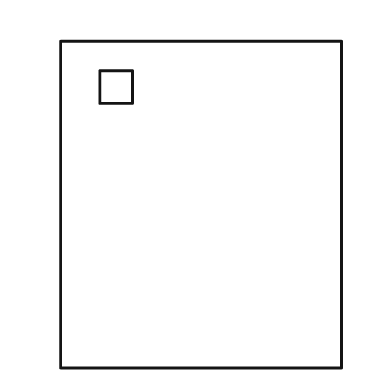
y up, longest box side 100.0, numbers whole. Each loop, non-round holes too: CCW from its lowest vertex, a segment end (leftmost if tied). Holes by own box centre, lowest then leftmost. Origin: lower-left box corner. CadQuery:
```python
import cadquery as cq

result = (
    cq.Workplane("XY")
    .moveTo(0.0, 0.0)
    .lineTo(86.0, 0.0)
    .lineTo(86.0, 100.0)
    .lineTo(0.0, 100.0)
    .close()
    .moveTo(12.0, 81.0)
    .lineTo(22.0, 81.0)
    .lineTo(22.0, 91.0)
    .lineTo(12.0, 91.0)
    .close()
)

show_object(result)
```